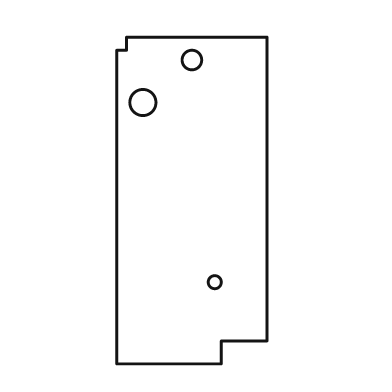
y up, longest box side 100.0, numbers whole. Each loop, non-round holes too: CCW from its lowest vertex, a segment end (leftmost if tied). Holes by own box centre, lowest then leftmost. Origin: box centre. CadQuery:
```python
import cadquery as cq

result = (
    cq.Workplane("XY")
    .moveTo(-23.0, -50.0)
    .lineTo(9.0, -50.0)
    .lineTo(9.0, -43.0)
    .lineTo(23.0, -43.0)
    .lineTo(23.0, 50.0)
    .lineTo(-20.0, 50.0)
    .lineTo(-20.0, 46.0)
    .lineTo(-23.0, 46.0)
    .close()
    .moveTo(7.0, -25.0)
    .circle(2.0)
    .moveTo(-15.0, 30.0)
    .circle(4.0)
    .moveTo(0.0, 43.0)
    .circle(3.0)
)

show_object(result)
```